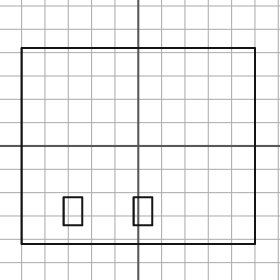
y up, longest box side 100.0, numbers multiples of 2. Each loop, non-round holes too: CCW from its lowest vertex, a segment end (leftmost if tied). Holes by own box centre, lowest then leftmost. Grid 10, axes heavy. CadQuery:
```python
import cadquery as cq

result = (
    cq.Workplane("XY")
    .moveTo(-50.0, -42.0)
    .lineTo(50.0, -42.0)
    .lineTo(50.0, 42.0)
    .lineTo(-50.0, 42.0)
    .close()
    .moveTo(-32.0, -34.0)
    .lineTo(-24.0, -34.0)
    .lineTo(-24.0, -22.0)
    .lineTo(-32.0, -22.0)
    .close()
    .moveTo(-2.0, -34.0)
    .lineTo(6.0, -34.0)
    .lineTo(6.0, -22.0)
    .lineTo(-2.0, -22.0)
    .close()
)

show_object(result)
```